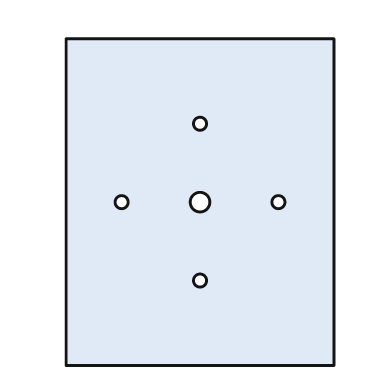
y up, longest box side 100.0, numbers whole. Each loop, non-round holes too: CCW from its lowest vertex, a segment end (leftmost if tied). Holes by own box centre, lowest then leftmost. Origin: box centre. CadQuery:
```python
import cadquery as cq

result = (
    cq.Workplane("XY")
    .moveTo(-41.0, -50.0)
    .lineTo(41.0, -50.0)
    .lineTo(41.0, 50.0)
    .lineTo(-41.0, 50.0)
    .close()
    .moveTo(0.0, -24.0)
    .circle(2.0)
    .moveTo(-24.0, 0.0)
    .circle(2.0)
    .moveTo(0.0, 0.0)
    .circle(3.0)
    .moveTo(24.0, 0.0)
    .circle(2.0)
    .moveTo(0.0, 24.0)
    .circle(2.0)
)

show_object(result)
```